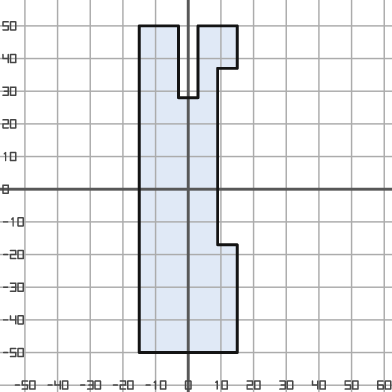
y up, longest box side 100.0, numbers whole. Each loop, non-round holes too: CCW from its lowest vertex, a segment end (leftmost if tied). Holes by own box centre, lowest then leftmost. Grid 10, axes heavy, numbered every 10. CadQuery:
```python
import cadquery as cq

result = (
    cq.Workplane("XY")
    .moveTo(-15.0, -50.0)
    .lineTo(15.0, -50.0)
    .lineTo(15.0, -17.0)
    .lineTo(9.0, -17.0)
    .lineTo(9.0, 37.0)
    .lineTo(15.0, 37.0)
    .lineTo(15.0, 50.0)
    .lineTo(3.0, 50.0)
    .lineTo(3.0, 28.0)
    .lineTo(-3.0, 28.0)
    .lineTo(-3.0, 50.0)
    .lineTo(-15.0, 50.0)
    .close()
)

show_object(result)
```